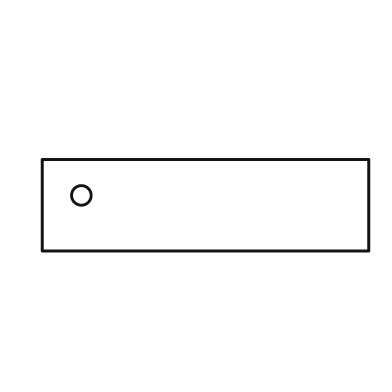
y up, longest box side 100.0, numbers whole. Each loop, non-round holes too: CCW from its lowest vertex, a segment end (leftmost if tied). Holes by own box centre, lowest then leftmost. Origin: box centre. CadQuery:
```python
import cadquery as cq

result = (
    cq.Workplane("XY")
    .moveTo(-50.0, -14.0)
    .lineTo(50.0, -14.0)
    .lineTo(50.0, 14.0)
    .lineTo(-50.0, 14.0)
    .close()
    .moveTo(-38.0, 3.0)
    .circle(3.0)
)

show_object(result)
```